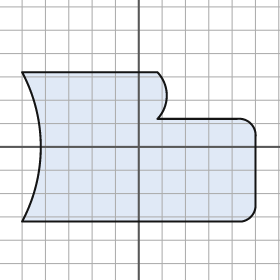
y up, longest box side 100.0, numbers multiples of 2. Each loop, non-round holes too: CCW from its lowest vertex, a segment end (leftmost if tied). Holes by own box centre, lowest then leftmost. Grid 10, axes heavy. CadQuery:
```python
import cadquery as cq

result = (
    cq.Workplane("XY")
    .moveTo(-50.0, -32.0)
    .lineTo(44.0, -32.0)
    .threePointArc((48.0, -30.0), (50.0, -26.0))
    .lineTo(50.0, 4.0)
    .threePointArc((48.0, 10.0), (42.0, 12.0))
    .lineTo(8.0, 12.0)
    .threePointArc((12.0, 22.0), (8.0, 32.0))
    .lineTo(-50.0, 32.0)
    .threePointArc((-42.0, 0.0), (-50.0, -32.0))
    .close()
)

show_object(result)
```